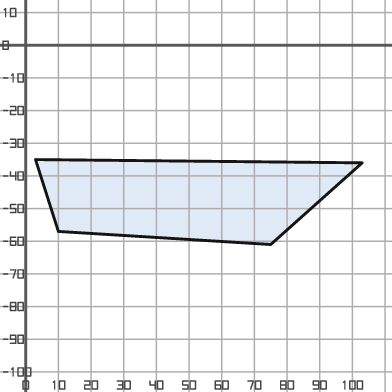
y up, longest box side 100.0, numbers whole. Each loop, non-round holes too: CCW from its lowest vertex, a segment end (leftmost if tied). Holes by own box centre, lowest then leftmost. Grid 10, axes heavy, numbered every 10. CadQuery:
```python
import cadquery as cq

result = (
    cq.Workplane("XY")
    .moveTo(75.0, -61.0)
    .lineTo(103.0, -36.0)
    .lineTo(3.0, -35.0)
    .lineTo(10.0, -57.0)
    .close()
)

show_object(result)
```